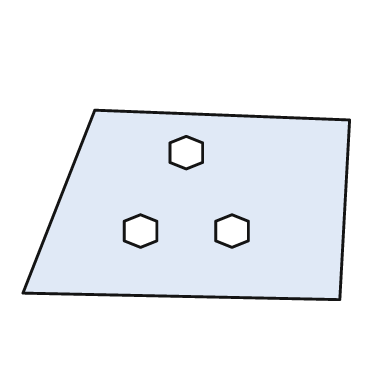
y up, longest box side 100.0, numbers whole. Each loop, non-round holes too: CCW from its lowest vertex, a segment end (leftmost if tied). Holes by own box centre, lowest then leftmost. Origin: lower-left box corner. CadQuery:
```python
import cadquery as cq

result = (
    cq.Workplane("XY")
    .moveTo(97.0, 0.0)
    .lineTo(100.0, 55.0)
    .lineTo(22.0, 58.0)
    .lineTo(0.0, 2.0)
    .close()
    .moveTo(36.0, 16.0)
    .lineTo(41.0, 18.0)
    .lineTo(41.0, 24.0)
    .lineTo(36.0, 26.0)
    .lineTo(31.0, 24.0)
    .lineTo(31.0, 18.0)
    .close()
    .moveTo(64.0, 16.0)
    .lineTo(69.0, 18.0)
    .lineTo(69.0, 24.0)
    .lineTo(64.0, 26.0)
    .lineTo(59.0, 24.0)
    .lineTo(59.0, 18.0)
    .close()
    .moveTo(50.0, 40.0)
    .lineTo(55.0, 42.0)
    .lineTo(55.0, 48.0)
    .lineTo(50.0, 50.0)
    .lineTo(45.0, 48.0)
    .lineTo(45.0, 42.0)
    .close()
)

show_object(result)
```